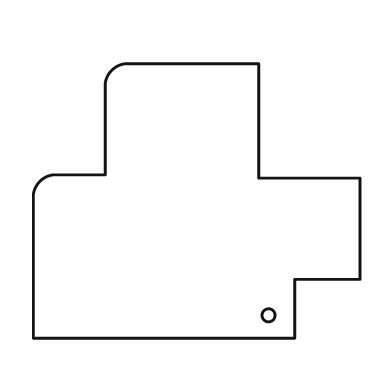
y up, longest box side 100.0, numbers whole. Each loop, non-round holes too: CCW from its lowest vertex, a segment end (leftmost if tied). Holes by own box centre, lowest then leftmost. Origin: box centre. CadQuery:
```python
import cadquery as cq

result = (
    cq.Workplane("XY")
    .moveTo(-50.0, -42.0)
    .lineTo(30.0, -42.0)
    .lineTo(30.0, -24.0)
    .lineTo(50.0, -24.0)
    .lineTo(50.0, 7.0)
    .lineTo(19.0, 7.0)
    .lineTo(19.0, 42.0)
    .lineTo(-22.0, 42.0)
    .threePointArc((-26.0, 40.0), (-28.0, 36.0))
    .lineTo(-28.0, 8.0)
    .lineTo(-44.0, 8.0)
    .threePointArc((-48.0, 6.0), (-50.0, 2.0))
    .close()
    .moveTo(22.0, -35.0)
    .circle(2.0)
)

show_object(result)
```